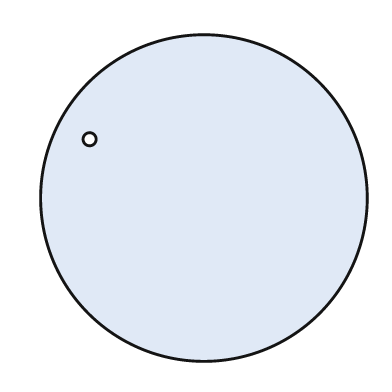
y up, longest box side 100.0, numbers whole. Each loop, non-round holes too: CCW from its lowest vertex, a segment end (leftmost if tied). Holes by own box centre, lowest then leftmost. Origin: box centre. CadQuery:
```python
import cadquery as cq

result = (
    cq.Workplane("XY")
    .moveTo(0.0, 0.0)
    .circle(50.0)
    .moveTo(-35.0, 18.0)
    .circle(2.0)
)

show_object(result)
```